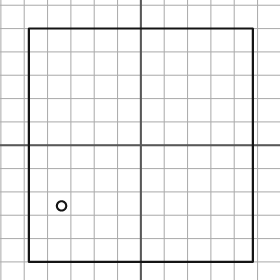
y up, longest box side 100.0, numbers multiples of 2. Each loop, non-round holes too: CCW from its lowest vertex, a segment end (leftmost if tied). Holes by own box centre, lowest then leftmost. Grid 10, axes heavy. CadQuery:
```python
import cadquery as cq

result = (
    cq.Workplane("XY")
    .moveTo(-48.0, -50.0)
    .lineTo(48.0, -50.0)
    .lineTo(48.0, 50.0)
    .lineTo(-48.0, 50.0)
    .close()
    .moveTo(-34.0, -26.0)
    .circle(2.0)
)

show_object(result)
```